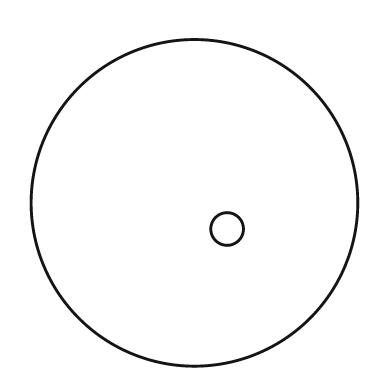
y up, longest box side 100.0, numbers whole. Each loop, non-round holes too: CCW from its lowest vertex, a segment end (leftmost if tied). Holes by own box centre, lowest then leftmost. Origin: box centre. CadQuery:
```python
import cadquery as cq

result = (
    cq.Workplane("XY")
    .moveTo(0.0, 0.0)
    .circle(50.0)
    .moveTo(10.0, -8.0)
    .circle(5.0)
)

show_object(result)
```